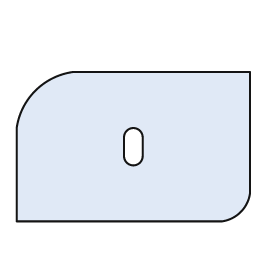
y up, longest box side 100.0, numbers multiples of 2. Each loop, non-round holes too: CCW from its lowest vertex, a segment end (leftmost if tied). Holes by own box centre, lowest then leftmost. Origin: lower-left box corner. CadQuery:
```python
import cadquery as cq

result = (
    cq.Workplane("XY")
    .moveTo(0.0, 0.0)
    .lineTo(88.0, 0.0)
    .threePointArc((96.0, 4.0), (100.0, 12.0))
    .lineTo(100.0, 64.0)
    .lineTo(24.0, 64.0)
    .threePointArc((8.0, 56.0), (0.0, 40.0))
    .close()
    .moveTo(46.0, 28.0)
    .threePointArc((50.0, 24.0), (54.0, 28.0))
    .lineTo(54.0, 36.0)
    .threePointArc((50.0, 40.0), (46.0, 36.0))
    .close()
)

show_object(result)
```